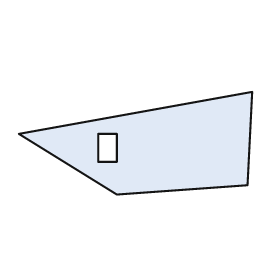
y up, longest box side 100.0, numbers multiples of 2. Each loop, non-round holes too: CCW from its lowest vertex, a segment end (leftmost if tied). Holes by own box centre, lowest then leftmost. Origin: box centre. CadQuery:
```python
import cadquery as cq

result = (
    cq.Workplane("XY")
    .moveTo(-8.0, -22.0)
    .lineTo(48.0, -18.0)
    .lineTo(50.0, 22.0)
    .lineTo(-50.0, 4.0)
    .close()
    .moveTo(-16.0, -8.0)
    .lineTo(-8.0, -8.0)
    .lineTo(-8.0, 4.0)
    .lineTo(-16.0, 4.0)
    .close()
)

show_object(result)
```